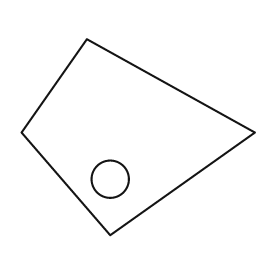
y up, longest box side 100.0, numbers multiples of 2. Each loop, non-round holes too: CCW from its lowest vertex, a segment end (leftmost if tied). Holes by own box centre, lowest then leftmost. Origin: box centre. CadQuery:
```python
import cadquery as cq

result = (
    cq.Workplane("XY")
    .moveTo(-12.0, -42.0)
    .lineTo(50.0, 2.0)
    .lineTo(-22.0, 42.0)
    .lineTo(-50.0, 2.0)
    .close()
    .moveTo(-12.0, -18.0)
    .circle(8.0)
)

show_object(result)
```